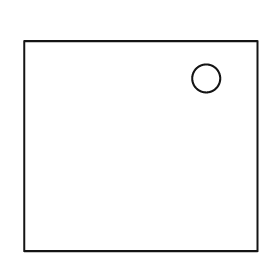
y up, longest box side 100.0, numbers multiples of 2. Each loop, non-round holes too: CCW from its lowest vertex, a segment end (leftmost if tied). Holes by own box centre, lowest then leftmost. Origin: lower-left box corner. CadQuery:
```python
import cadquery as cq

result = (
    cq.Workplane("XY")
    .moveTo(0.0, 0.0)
    .lineTo(100.0, 0.0)
    .lineTo(100.0, 90.0)
    .lineTo(0.0, 90.0)
    .close()
    .moveTo(78.0, 74.0)
    .circle(6.0)
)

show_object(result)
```